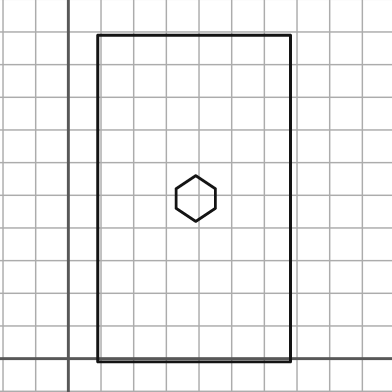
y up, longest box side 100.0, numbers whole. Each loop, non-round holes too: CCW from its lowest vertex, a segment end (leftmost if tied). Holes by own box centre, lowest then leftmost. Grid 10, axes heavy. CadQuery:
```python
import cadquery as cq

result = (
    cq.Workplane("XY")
    .moveTo(9.0, -1.0)
    .lineTo(68.0, -1.0)
    .lineTo(68.0, 99.0)
    .lineTo(9.0, 99.0)
    .close()
    .moveTo(39.0, 42.0)
    .lineTo(45.0, 46.0)
    .lineTo(45.0, 52.0)
    .lineTo(39.0, 56.0)
    .lineTo(33.0, 52.0)
    .lineTo(33.0, 46.0)
    .close()
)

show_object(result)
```